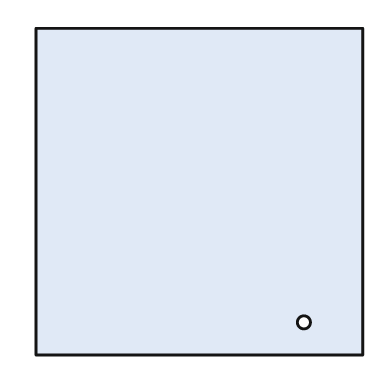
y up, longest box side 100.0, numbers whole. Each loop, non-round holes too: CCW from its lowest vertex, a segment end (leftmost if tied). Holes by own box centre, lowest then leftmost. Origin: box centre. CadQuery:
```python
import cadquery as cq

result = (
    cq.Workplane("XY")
    .moveTo(-50.0, -50.0)
    .lineTo(50.0, -50.0)
    .lineTo(50.0, 50.0)
    .lineTo(-50.0, 50.0)
    .close()
    .moveTo(32.0, -40.0)
    .circle(2.0)
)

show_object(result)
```